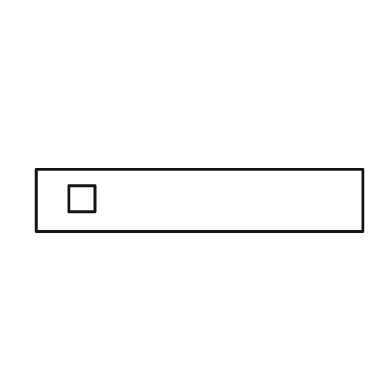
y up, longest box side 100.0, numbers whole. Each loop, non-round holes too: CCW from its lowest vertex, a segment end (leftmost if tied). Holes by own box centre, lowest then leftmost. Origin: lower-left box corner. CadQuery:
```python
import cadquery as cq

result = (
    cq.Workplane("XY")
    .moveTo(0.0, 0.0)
    .lineTo(100.0, 0.0)
    .lineTo(100.0, 19.0)
    .lineTo(0.0, 19.0)
    .close()
    .moveTo(10.0, 6.0)
    .lineTo(18.0, 6.0)
    .lineTo(18.0, 14.0)
    .lineTo(10.0, 14.0)
    .close()
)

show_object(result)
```